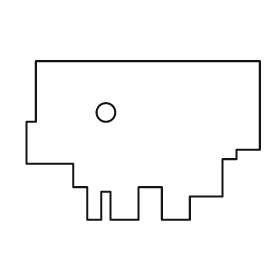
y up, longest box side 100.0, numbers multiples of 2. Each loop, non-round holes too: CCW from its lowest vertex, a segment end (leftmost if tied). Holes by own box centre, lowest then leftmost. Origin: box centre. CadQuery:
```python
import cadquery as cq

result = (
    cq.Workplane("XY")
    .moveTo(-24.0, -34.0)
    .lineTo(-18.0, -34.0)
    .lineTo(-18.0, -22.0)
    .lineTo(-14.0, -22.0)
    .lineTo(-14.0, -34.0)
    .lineTo(-2.0, -34.0)
    .lineTo(-2.0, -20.0)
    .lineTo(8.0, -20.0)
    .lineTo(8.0, -34.0)
    .lineTo(20.0, -34.0)
    .lineTo(20.0, -24.0)
    .lineTo(34.0, -24.0)
    .lineTo(34.0, -8.0)
    .lineTo(40.0, -8.0)
    .lineTo(40.0, -4.0)
    .lineTo(50.0, -4.0)
    .lineTo(50.0, 34.0)
    .lineTo(-46.0, 34.0)
    .lineTo(-46.0, 8.0)
    .lineTo(-50.0, 8.0)
    .lineTo(-50.0, -10.0)
    .lineTo(-30.0, -10.0)
    .lineTo(-30.0, -20.0)
    .lineTo(-24.0, -20.0)
    .close()
    .moveTo(-16.0, 12.0)
    .circle(4.0)
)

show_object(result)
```